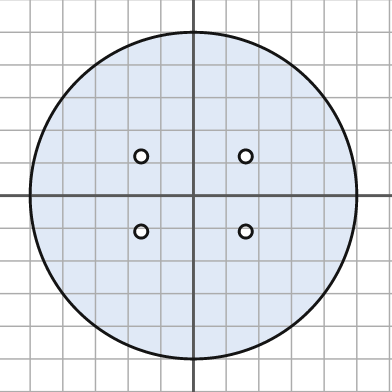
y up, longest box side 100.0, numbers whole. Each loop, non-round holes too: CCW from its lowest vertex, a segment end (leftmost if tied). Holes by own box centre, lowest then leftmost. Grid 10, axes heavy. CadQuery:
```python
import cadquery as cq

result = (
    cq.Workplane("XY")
    .moveTo(0.0, 0.0)
    .circle(50.0)
    .moveTo(-16.0, -11.0)
    .circle(2.0)
    .moveTo(16.0, -11.0)
    .circle(2.0)
    .moveTo(-16.0, 12.0)
    .circle(2.0)
    .moveTo(16.0, 12.0)
    .circle(2.0)
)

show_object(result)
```